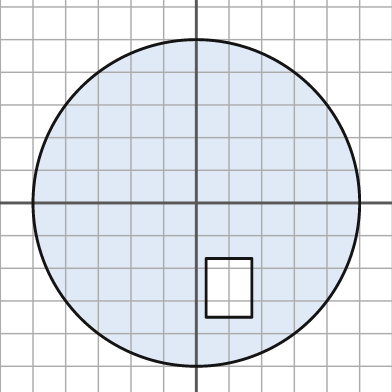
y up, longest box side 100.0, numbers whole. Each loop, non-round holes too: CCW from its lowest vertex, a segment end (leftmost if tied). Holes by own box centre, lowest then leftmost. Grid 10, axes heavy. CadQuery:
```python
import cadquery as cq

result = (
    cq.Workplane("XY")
    .moveTo(0.0, 0.0)
    .circle(50.0)
    .moveTo(3.0, -35.0)
    .lineTo(17.0, -35.0)
    .lineTo(17.0, -17.0)
    .lineTo(3.0, -17.0)
    .close()
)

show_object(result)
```